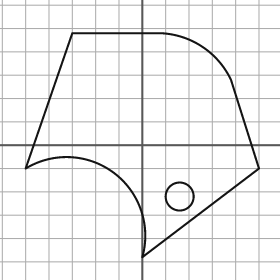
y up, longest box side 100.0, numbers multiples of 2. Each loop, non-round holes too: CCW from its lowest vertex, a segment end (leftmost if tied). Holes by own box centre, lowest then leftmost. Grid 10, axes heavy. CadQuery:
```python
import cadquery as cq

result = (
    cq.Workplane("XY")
    .moveTo(0.0, -48.0)
    .lineTo(50.0, -10.0)
    .lineTo(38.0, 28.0)
    .threePointArc((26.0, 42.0), (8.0, 48.0))
    .lineTo(-30.0, 48.0)
    .lineTo(-50.0, -10.0)
    .threePointArc((-12.0, -12.0), (0.0, -48.0))
    .close()
    .moveTo(16.0, -22.0)
    .circle(6.0)
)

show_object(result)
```